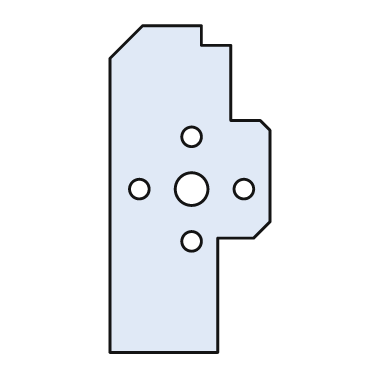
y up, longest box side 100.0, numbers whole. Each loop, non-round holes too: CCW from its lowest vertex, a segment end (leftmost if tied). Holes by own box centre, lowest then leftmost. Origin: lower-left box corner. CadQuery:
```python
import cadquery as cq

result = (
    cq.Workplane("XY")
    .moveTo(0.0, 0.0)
    .lineTo(33.0, 0.0)
    .lineTo(33.0, 35.0)
    .lineTo(44.0, 35.0)
    .lineTo(49.0, 40.0)
    .lineTo(49.0, 68.0)
    .lineTo(46.0, 71.0)
    .lineTo(37.0, 71.0)
    .lineTo(37.0, 94.0)
    .lineTo(28.0, 94.0)
    .lineTo(28.0, 100.0)
    .lineTo(10.0, 100.0)
    .lineTo(0.0, 90.0)
    .close()
    .moveTo(25.0, 34.0)
    .circle(3.0)
    .moveTo(9.0, 50.0)
    .circle(3.0)
    .moveTo(25.0, 50.0)
    .circle(5.0)
    .moveTo(41.0, 50.0)
    .circle(3.0)
    .moveTo(25.0, 66.0)
    .circle(3.0)
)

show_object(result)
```